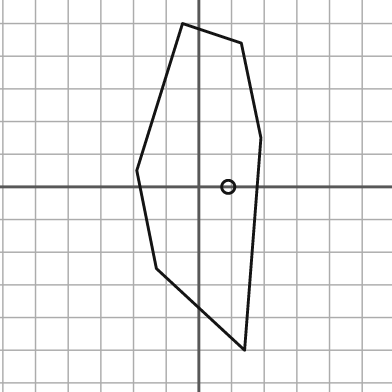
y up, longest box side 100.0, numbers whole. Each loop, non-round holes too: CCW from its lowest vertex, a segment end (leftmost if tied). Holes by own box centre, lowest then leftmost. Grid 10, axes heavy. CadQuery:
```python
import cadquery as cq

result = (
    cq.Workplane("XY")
    .moveTo(14.0, -50.0)
    .lineTo(19.0, 15.0)
    .lineTo(13.0, 44.0)
    .lineTo(-5.0, 50.0)
    .lineTo(-19.0, 5.0)
    .lineTo(-13.0, -25.0)
    .close()
    .moveTo(9.0, 0.0)
    .circle(2.0)
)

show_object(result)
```